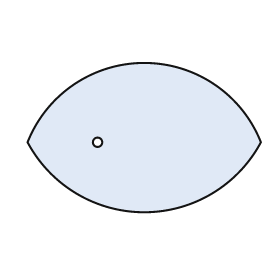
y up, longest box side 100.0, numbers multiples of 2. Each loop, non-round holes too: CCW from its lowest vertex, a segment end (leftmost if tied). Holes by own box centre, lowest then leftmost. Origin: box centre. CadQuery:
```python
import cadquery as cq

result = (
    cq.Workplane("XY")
    .moveTo(-50.0, -2.0)
    .threePointArc((0.0, -32.0), (50.0, -2.0))
    .threePointArc((0.0, 32.0), (-50.0, -2.0))
    .close()
    .moveTo(-20.0, -2.0)
    .circle(2.0)
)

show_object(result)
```